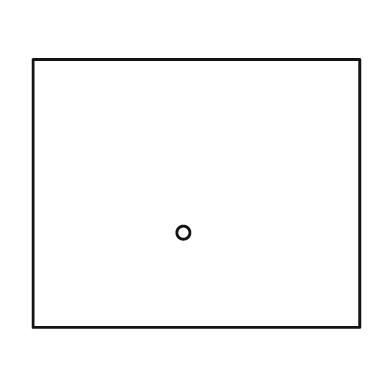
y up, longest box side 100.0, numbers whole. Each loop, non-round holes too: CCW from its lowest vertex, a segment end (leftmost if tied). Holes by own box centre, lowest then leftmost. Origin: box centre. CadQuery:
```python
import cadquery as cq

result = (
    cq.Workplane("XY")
    .moveTo(-50.0, -41.0)
    .lineTo(50.0, -41.0)
    .lineTo(50.0, 41.0)
    .lineTo(-50.0, 41.0)
    .close()
    .moveTo(-4.0, -12.0)
    .circle(2.0)
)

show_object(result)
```